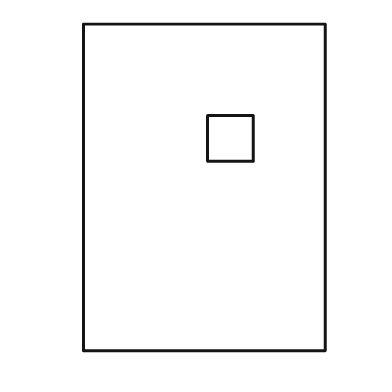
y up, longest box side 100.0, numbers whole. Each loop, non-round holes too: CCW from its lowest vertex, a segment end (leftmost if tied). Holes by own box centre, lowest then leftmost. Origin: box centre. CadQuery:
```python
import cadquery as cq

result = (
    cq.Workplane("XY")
    .moveTo(-37.0, -50.0)
    .lineTo(37.0, -50.0)
    .lineTo(37.0, 50.0)
    .lineTo(-37.0, 50.0)
    .close()
    .moveTo(1.0, 8.0)
    .lineTo(15.0, 8.0)
    .lineTo(15.0, 22.0)
    .lineTo(1.0, 22.0)
    .close()
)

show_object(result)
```